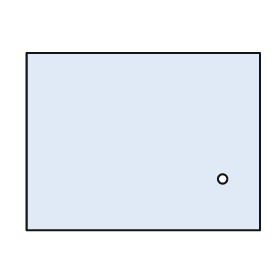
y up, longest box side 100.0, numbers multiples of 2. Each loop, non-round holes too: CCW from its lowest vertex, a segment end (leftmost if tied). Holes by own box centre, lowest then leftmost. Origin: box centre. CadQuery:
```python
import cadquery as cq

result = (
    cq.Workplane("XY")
    .moveTo(-50.0, -38.0)
    .lineTo(50.0, -38.0)
    .lineTo(50.0, 38.0)
    .lineTo(-50.0, 38.0)
    .close()
    .moveTo(34.0, -16.0)
    .circle(2.0)
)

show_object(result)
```